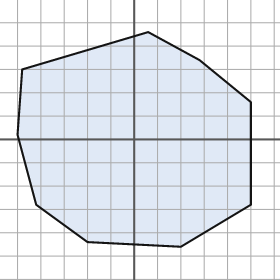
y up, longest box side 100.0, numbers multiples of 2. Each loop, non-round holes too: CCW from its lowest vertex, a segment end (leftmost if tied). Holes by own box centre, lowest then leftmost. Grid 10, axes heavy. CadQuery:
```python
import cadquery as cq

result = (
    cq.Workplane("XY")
    .moveTo(20.0, -46.0)
    .lineTo(50.0, -28.0)
    .lineTo(50.0, 16.0)
    .lineTo(28.0, 34.0)
    .lineTo(6.0, 46.0)
    .lineTo(-48.0, 30.0)
    .lineTo(-50.0, 2.0)
    .lineTo(-42.0, -28.0)
    .lineTo(-20.0, -44.0)
    .close()
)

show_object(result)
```